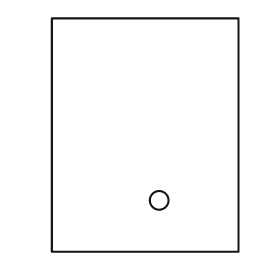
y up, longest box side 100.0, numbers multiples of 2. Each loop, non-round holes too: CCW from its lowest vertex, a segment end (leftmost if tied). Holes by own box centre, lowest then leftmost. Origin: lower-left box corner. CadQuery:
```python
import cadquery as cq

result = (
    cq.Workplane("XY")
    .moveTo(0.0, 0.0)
    .lineTo(80.0, 0.0)
    .lineTo(80.0, 100.0)
    .lineTo(0.0, 100.0)
    .close()
    .moveTo(46.0, 22.0)
    .circle(4.0)
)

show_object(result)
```